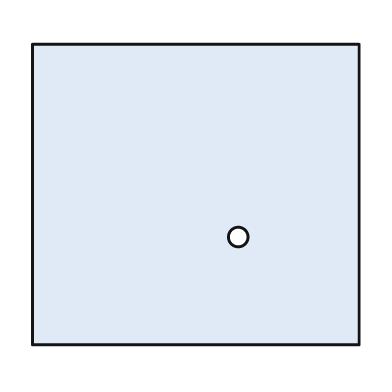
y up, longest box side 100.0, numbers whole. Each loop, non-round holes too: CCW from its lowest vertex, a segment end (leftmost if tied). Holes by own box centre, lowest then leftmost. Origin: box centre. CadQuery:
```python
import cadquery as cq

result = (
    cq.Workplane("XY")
    .moveTo(-50.0, -46.0)
    .lineTo(50.0, -46.0)
    .lineTo(50.0, 46.0)
    .lineTo(-50.0, 46.0)
    .close()
    .moveTo(13.0, -13.0)
    .circle(3.0)
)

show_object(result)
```